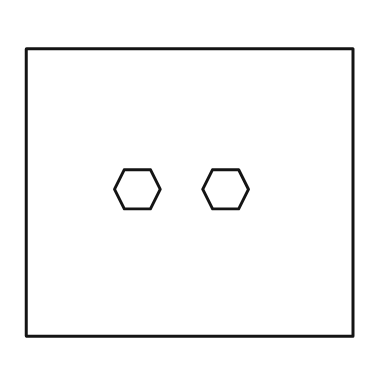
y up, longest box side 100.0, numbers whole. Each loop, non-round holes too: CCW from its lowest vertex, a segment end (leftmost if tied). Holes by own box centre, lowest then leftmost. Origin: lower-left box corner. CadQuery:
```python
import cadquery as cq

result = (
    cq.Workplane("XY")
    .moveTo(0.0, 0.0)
    .lineTo(100.0, 0.0)
    .lineTo(100.0, 88.0)
    .lineTo(0.0, 88.0)
    .close()
    .moveTo(30.0, 39.0)
    .lineTo(38.0, 39.0)
    .lineTo(41.0, 45.0)
    .lineTo(38.0, 51.0)
    .lineTo(30.0, 51.0)
    .lineTo(27.0, 45.0)
    .close()
    .moveTo(57.0, 39.0)
    .lineTo(65.0, 39.0)
    .lineTo(68.0, 45.0)
    .lineTo(65.0, 51.0)
    .lineTo(57.0, 51.0)
    .lineTo(54.0, 45.0)
    .close()
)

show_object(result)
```